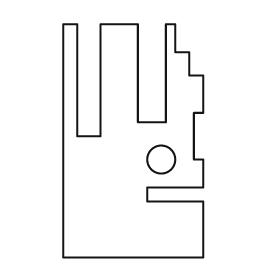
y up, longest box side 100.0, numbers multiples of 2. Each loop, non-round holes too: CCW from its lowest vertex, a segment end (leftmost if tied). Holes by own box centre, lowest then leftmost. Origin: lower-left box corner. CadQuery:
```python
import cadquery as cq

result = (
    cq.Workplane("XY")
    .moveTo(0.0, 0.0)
    .lineTo(60.0, 0.0)
    .lineTo(60.0, 24.0)
    .lineTo(36.0, 24.0)
    .lineTo(36.0, 30.0)
    .lineTo(60.0, 30.0)
    .lineTo(60.0, 42.0)
    .lineTo(56.0, 42.0)
    .lineTo(56.0, 62.0)
    .lineTo(60.0, 62.0)
    .lineTo(60.0, 78.0)
    .lineTo(54.0, 78.0)
    .lineTo(54.0, 88.0)
    .lineTo(48.0, 88.0)
    .lineTo(48.0, 100.0)
    .lineTo(44.0, 100.0)
    .lineTo(44.0, 58.0)
    .lineTo(32.0, 58.0)
    .lineTo(32.0, 100.0)
    .lineTo(16.0, 100.0)
    .lineTo(16.0, 52.0)
    .lineTo(6.0, 52.0)
    .lineTo(6.0, 100.0)
    .lineTo(0.0, 100.0)
    .close()
    .moveTo(42.0, 42.0)
    .circle(6.0)
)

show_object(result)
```